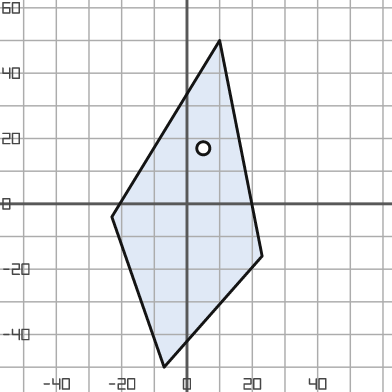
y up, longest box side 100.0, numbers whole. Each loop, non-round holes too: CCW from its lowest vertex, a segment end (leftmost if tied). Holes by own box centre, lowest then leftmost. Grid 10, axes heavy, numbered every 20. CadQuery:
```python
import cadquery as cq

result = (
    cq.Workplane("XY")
    .moveTo(-7.0, -50.0)
    .lineTo(23.0, -16.0)
    .lineTo(10.0, 50.0)
    .lineTo(-23.0, -4.0)
    .close()
    .moveTo(5.0, 17.0)
    .circle(2.0)
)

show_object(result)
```